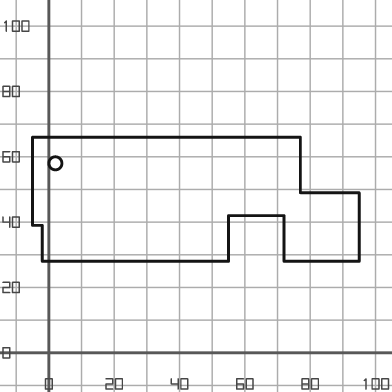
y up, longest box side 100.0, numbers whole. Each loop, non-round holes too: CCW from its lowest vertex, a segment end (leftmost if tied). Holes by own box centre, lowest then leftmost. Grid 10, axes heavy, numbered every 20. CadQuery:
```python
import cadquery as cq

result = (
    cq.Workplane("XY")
    .moveTo(-2.0, 28.0)
    .lineTo(55.0, 28.0)
    .lineTo(55.0, 42.0)
    .lineTo(72.0, 42.0)
    .lineTo(72.0, 28.0)
    .lineTo(95.0, 28.0)
    .lineTo(95.0, 49.0)
    .lineTo(77.0, 49.0)
    .lineTo(77.0, 66.0)
    .lineTo(-5.0, 66.0)
    .lineTo(-5.0, 39.0)
    .lineTo(-2.0, 39.0)
    .close()
    .moveTo(2.0, 58.0)
    .circle(2.0)
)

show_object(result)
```